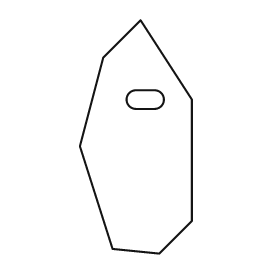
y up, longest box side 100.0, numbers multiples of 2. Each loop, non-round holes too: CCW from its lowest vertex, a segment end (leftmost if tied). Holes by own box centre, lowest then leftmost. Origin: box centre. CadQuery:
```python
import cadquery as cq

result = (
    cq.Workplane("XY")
    .moveTo(10.0, -50.0)
    .lineTo(24.0, -36.0)
    .lineTo(24.0, 16.0)
    .lineTo(2.0, 50.0)
    .lineTo(-14.0, 34.0)
    .lineTo(-24.0, -4.0)
    .lineTo(-10.0, -48.0)
    .close()
    .moveTo(0.0, 12.0)
    .lineTo(8.0, 12.0)
    .threePointArc((12.0, 16.0), (8.0, 20.0))
    .lineTo(0.0, 20.0)
    .threePointArc((-4.0, 16.0), (0.0, 12.0))
    .close()
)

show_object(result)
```